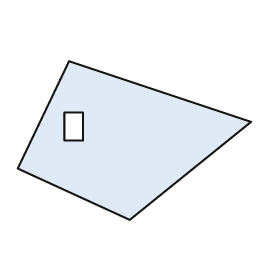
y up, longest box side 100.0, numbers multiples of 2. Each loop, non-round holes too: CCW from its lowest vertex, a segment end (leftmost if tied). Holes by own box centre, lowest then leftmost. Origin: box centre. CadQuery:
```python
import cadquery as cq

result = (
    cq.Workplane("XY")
    .moveTo(-2.0, -34.0)
    .lineTo(50.0, 8.0)
    .lineTo(-28.0, 34.0)
    .lineTo(-50.0, -12.0)
    .close()
    .moveTo(-30.0, 0.0)
    .lineTo(-22.0, 0.0)
    .lineTo(-22.0, 12.0)
    .lineTo(-30.0, 12.0)
    .close()
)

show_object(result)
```